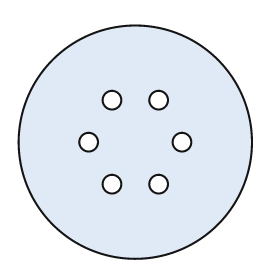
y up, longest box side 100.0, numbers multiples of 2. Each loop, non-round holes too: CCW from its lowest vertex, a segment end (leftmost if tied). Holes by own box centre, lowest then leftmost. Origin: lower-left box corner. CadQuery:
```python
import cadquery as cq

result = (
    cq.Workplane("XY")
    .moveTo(50.0, 50.0)
    .circle(50.0)
    .moveTo(40.0, 32.0)
    .circle(4.0)
    .moveTo(60.0, 32.0)
    .circle(4.0)
    .moveTo(30.0, 50.0)
    .circle(4.0)
    .moveTo(70.0, 50.0)
    .circle(4.0)
    .moveTo(40.0, 68.0)
    .circle(4.0)
    .moveTo(60.0, 68.0)
    .circle(4.0)
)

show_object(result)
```